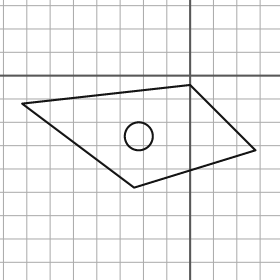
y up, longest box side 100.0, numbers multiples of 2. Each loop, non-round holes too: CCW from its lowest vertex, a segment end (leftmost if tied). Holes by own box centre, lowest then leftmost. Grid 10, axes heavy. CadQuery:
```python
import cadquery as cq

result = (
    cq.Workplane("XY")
    .moveTo(-24.0, -48.0)
    .lineTo(28.0, -32.0)
    .lineTo(0.0, -4.0)
    .lineTo(-72.0, -12.0)
    .close()
    .moveTo(-22.0, -26.0)
    .circle(6.0)
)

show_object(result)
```